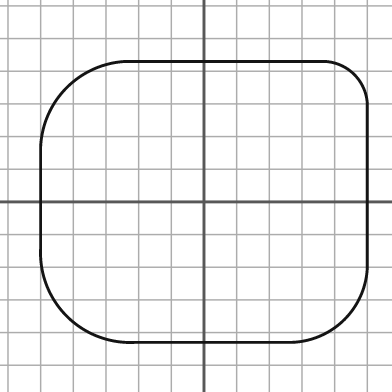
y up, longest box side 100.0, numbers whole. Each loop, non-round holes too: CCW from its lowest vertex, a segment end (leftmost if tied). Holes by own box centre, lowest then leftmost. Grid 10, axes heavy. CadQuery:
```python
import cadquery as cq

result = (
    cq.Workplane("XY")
    .moveTo(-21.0, -43.0)
    .lineTo(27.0, -43.0)
    .threePointArc((43.0, -36.0), (50.0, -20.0))
    .lineTo(50.0, 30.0)
    .threePointArc((46.0, 39.0), (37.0, 43.0))
    .lineTo(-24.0, 43.0)
    .threePointArc((-42.0, 35.0), (-50.0, 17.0))
    .lineTo(-50.0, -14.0)
    .threePointArc((-42.0, -35.0), (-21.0, -43.0))
    .close()
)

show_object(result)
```